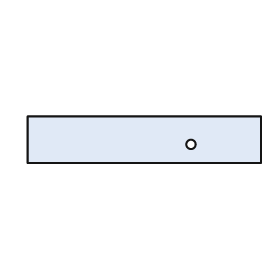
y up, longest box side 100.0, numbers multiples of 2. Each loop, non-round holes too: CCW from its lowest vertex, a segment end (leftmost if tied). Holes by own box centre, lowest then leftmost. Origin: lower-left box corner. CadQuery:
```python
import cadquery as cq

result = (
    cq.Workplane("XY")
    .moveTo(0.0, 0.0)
    .lineTo(100.0, 0.0)
    .lineTo(100.0, 20.0)
    .lineTo(0.0, 20.0)
    .close()
    .moveTo(70.0, 8.0)
    .circle(2.0)
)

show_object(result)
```